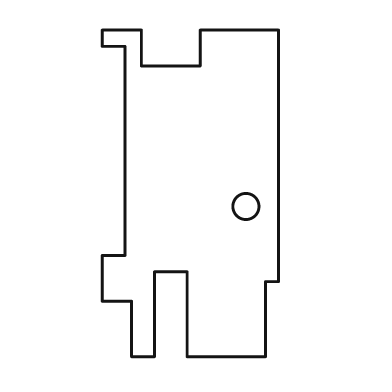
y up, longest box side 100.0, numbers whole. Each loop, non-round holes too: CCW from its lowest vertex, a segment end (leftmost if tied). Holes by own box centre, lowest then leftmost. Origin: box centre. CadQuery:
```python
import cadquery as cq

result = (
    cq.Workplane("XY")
    .moveTo(-18.0, -50.0)
    .lineTo(-11.0, -50.0)
    .lineTo(-11.0, -24.0)
    .lineTo(-1.0, -24.0)
    .lineTo(-1.0, -50.0)
    .lineTo(23.0, -50.0)
    .lineTo(23.0, -27.0)
    .lineTo(27.0, -27.0)
    .lineTo(27.0, 50.0)
    .lineTo(3.0, 50.0)
    .lineTo(3.0, 39.0)
    .lineTo(-15.0, 39.0)
    .lineTo(-15.0, 50.0)
    .lineTo(-27.0, 50.0)
    .lineTo(-27.0, 45.0)
    .lineTo(-20.0, 45.0)
    .lineTo(-20.0, -19.0)
    .lineTo(-27.0, -19.0)
    .lineTo(-27.0, -33.0)
    .lineTo(-18.0, -33.0)
    .close()
    .moveTo(17.0, -4.0)
    .circle(4.0)
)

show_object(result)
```